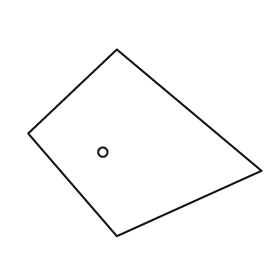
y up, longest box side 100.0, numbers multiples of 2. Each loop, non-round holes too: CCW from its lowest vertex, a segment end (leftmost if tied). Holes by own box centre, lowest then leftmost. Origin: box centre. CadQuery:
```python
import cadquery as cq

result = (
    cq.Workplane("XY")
    .moveTo(-12.0, -40.0)
    .lineTo(50.0, -12.0)
    .lineTo(-12.0, 40.0)
    .lineTo(-50.0, 4.0)
    .close()
    .moveTo(-18.0, -4.0)
    .circle(2.0)
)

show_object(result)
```